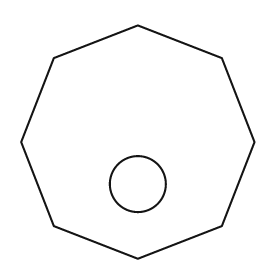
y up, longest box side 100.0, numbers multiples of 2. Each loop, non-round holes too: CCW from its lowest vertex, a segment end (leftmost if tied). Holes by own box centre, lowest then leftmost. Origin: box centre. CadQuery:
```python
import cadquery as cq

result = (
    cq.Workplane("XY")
    .moveTo(0.0, -50.0)
    .lineTo(36.0, -36.0)
    .lineTo(50.0, 0.0)
    .lineTo(36.0, 36.0)
    .lineTo(0.0, 50.0)
    .lineTo(-36.0, 36.0)
    .lineTo(-50.0, 0.0)
    .lineTo(-36.0, -36.0)
    .close()
    .moveTo(0.0, -18.0)
    .circle(12.0)
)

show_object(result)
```